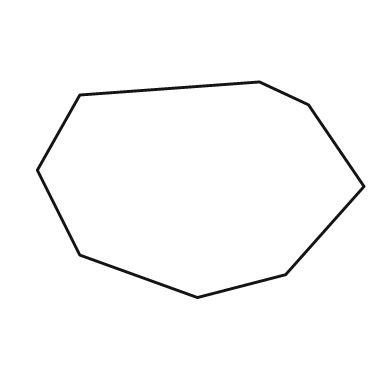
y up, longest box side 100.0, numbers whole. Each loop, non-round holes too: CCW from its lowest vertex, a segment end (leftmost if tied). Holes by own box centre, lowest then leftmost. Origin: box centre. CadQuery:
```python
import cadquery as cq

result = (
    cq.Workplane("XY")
    .moveTo(-1.0, -33.0)
    .lineTo(26.0, -26.0)
    .lineTo(50.0, 1.0)
    .lineTo(33.0, 26.0)
    .lineTo(18.0, 33.0)
    .lineTo(-37.0, 29.0)
    .lineTo(-50.0, 6.0)
    .lineTo(-37.0, -20.0)
    .close()
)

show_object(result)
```